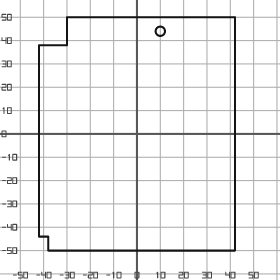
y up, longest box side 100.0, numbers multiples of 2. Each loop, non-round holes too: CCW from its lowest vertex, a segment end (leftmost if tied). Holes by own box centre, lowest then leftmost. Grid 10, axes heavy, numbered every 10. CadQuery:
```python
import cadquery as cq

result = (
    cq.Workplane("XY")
    .moveTo(-38.0, -50.0)
    .lineTo(42.0, -50.0)
    .lineTo(42.0, 50.0)
    .lineTo(-30.0, 50.0)
    .lineTo(-30.0, 38.0)
    .lineTo(-42.0, 38.0)
    .lineTo(-42.0, -44.0)
    .lineTo(-38.0, -44.0)
    .close()
    .moveTo(10.0, 44.0)
    .circle(2.0)
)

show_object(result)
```